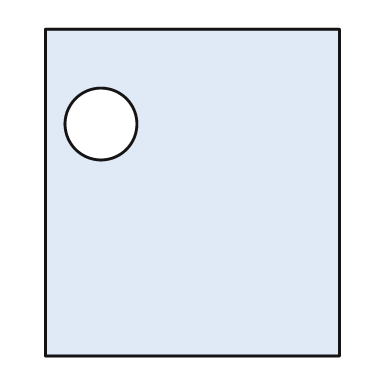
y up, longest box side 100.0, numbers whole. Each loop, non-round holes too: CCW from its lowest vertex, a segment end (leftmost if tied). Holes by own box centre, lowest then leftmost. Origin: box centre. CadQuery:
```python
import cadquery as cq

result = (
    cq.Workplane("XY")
    .moveTo(-45.0, -50.0)
    .lineTo(45.0, -50.0)
    .lineTo(45.0, 50.0)
    .lineTo(-45.0, 50.0)
    .close()
    .moveTo(-28.0, 21.0)
    .circle(11.0)
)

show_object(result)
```